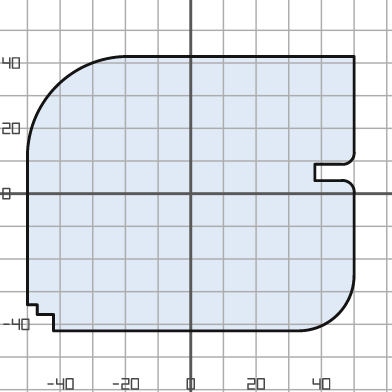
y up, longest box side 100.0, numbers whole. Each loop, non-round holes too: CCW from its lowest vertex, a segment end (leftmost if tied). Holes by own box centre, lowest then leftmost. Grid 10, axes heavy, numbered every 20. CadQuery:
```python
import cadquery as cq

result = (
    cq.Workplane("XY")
    .moveTo(-42.0, -42.0)
    .lineTo(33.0, -42.0)
    .threePointArc((45.0, -37.0), (50.0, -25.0))
    .lineTo(50.0, 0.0)
    .threePointArc((49.0, 3.0), (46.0, 4.0))
    .lineTo(38.0, 4.0)
    .lineTo(38.0, 9.0)
    .lineTo(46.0, 9.0)
    .threePointArc((49.0, 10.0), (50.0, 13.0))
    .lineTo(50.0, 42.0)
    .lineTo(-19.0, 42.0)
    .threePointArc((-41.0, 33.0), (-50.0, 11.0))
    .lineTo(-50.0, -34.0)
    .lineTo(-47.0, -34.0)
    .lineTo(-47.0, -37.0)
    .lineTo(-42.0, -37.0)
    .close()
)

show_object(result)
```